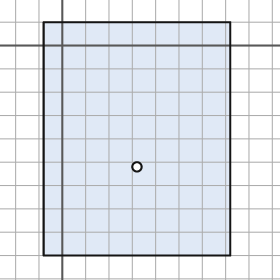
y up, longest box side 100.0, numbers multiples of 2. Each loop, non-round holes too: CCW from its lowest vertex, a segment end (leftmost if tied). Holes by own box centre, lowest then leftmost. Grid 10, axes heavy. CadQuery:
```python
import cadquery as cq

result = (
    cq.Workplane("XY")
    .moveTo(-8.0, -90.0)
    .lineTo(72.0, -90.0)
    .lineTo(72.0, 10.0)
    .lineTo(-8.0, 10.0)
    .close()
    .moveTo(32.0, -52.0)
    .circle(2.0)
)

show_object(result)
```